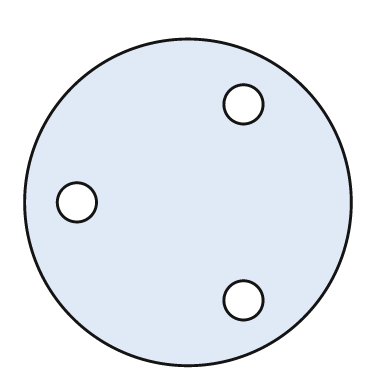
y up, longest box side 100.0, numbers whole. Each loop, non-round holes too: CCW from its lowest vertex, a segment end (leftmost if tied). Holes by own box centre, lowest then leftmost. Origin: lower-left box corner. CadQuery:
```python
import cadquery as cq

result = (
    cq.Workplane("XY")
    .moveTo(50.0, 50.0)
    .circle(50.0)
    .moveTo(67.0, 20.0)
    .circle(6.0)
    .moveTo(16.0, 50.0)
    .circle(6.0)
    .moveTo(67.0, 80.0)
    .circle(6.0)
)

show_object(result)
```